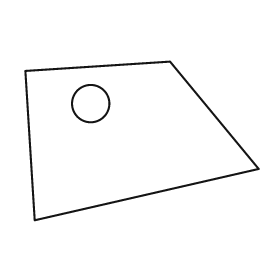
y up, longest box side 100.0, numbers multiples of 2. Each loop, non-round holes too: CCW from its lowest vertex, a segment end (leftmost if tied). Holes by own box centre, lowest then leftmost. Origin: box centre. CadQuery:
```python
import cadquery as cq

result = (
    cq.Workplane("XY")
    .moveTo(-46.0, -34.0)
    .lineTo(50.0, -12.0)
    .lineTo(12.0, 34.0)
    .lineTo(-50.0, 30.0)
    .close()
    .moveTo(-22.0, 16.0)
    .circle(8.0)
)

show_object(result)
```